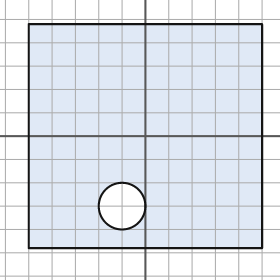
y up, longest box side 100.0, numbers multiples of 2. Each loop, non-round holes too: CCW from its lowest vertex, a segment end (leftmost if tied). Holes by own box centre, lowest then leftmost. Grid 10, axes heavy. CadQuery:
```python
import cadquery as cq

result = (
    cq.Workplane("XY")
    .moveTo(-50.0, -48.0)
    .lineTo(50.0, -48.0)
    .lineTo(50.0, 48.0)
    .lineTo(-50.0, 48.0)
    .close()
    .moveTo(-10.0, -30.0)
    .circle(10.0)
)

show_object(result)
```